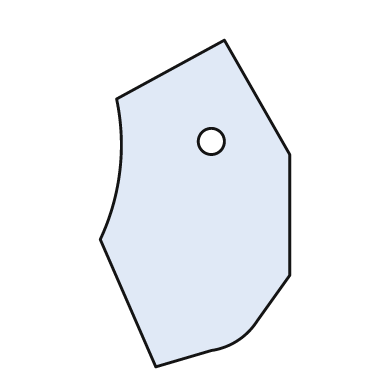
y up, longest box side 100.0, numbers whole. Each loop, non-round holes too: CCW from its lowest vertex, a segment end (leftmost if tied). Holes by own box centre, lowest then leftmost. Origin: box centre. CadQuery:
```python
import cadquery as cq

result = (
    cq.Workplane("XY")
    .moveTo(-12.0, -50.0)
    .lineTo(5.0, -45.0)
    .threePointArc((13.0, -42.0), (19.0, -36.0))
    .lineTo(29.0, -22.0)
    .lineTo(29.0, 15.0)
    .lineTo(9.0, 50.0)
    .lineTo(-24.0, 32.0)
    .threePointArc((-23.0, 10.0), (-29.0, -11.0))
    .close()
    .moveTo(5.0, 19.0)
    .circle(4.0)
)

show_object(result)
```